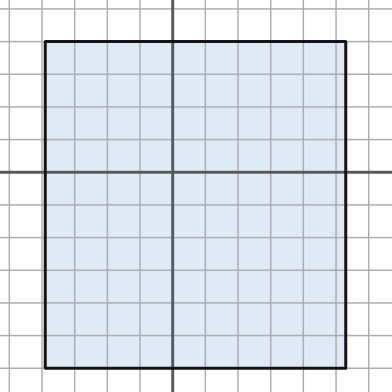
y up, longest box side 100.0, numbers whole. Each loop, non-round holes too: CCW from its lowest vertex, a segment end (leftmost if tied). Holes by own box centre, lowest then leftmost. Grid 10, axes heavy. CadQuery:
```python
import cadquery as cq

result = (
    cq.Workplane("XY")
    .moveTo(-39.0, -60.0)
    .lineTo(53.0, -60.0)
    .lineTo(53.0, 40.0)
    .lineTo(-39.0, 40.0)
    .close()
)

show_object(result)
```